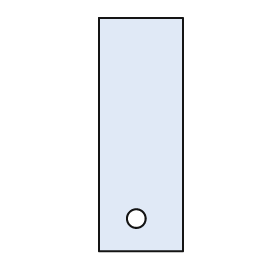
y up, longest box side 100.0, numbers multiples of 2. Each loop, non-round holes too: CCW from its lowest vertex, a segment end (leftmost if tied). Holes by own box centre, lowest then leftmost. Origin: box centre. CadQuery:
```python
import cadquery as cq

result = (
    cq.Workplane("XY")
    .moveTo(-18.0, -50.0)
    .lineTo(18.0, -50.0)
    .lineTo(18.0, 50.0)
    .lineTo(-18.0, 50.0)
    .close()
    .moveTo(-2.0, -36.0)
    .circle(4.0)
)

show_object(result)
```